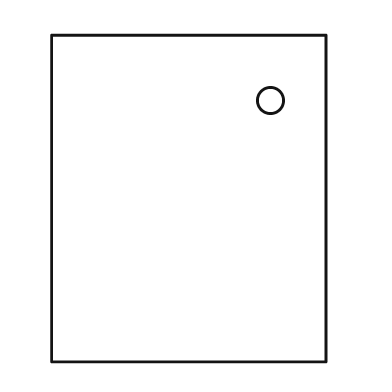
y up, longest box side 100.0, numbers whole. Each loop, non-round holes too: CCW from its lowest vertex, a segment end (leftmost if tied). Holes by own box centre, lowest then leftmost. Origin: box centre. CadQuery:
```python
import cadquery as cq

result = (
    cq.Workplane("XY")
    .moveTo(-42.0, -50.0)
    .lineTo(42.0, -50.0)
    .lineTo(42.0, 50.0)
    .lineTo(-42.0, 50.0)
    .close()
    .moveTo(25.0, 30.0)
    .circle(4.0)
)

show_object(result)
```